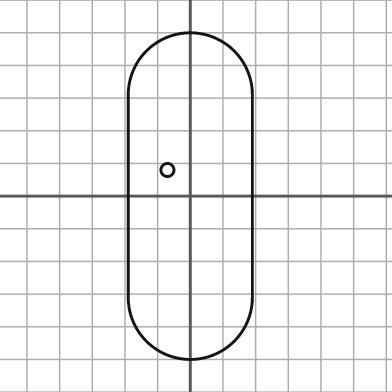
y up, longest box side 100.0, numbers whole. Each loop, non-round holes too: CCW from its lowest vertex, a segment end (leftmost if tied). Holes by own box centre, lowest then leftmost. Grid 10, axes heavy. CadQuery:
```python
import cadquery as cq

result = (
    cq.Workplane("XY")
    .moveTo(-19.0, -31.0)
    .threePointArc((0.0, -50.0), (19.0, -31.0))
    .lineTo(19.0, 31.0)
    .threePointArc((0.0, 50.0), (-19.0, 31.0))
    .close()
    .moveTo(-7.0, 8.0)
    .circle(2.0)
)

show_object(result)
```